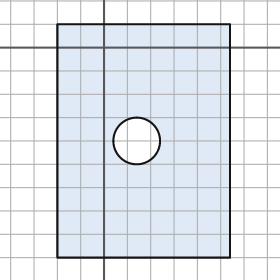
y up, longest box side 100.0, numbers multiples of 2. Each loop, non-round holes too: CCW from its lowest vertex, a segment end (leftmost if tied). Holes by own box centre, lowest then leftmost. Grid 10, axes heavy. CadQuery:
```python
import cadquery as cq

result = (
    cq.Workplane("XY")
    .moveTo(-20.0, -90.0)
    .lineTo(54.0, -90.0)
    .lineTo(54.0, 10.0)
    .lineTo(-20.0, 10.0)
    .close()
    .moveTo(14.0, -40.0)
    .circle(10.0)
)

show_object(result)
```